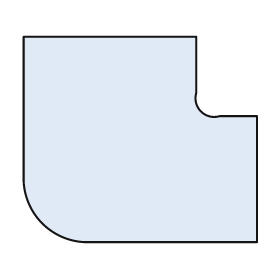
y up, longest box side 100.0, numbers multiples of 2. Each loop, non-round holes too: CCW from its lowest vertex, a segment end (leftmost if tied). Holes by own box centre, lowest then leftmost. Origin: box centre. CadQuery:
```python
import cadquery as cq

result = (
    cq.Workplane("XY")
    .moveTo(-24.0, -44.0)
    .lineTo(50.0, -44.0)
    .lineTo(50.0, 10.0)
    .lineTo(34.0, 10.0)
    .threePointArc((26.0, 12.0), (24.0, 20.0))
    .lineTo(24.0, 44.0)
    .lineTo(-50.0, 44.0)
    .lineTo(-50.0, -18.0)
    .threePointArc((-42.0, -36.0), (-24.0, -44.0))
    .close()
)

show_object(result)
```